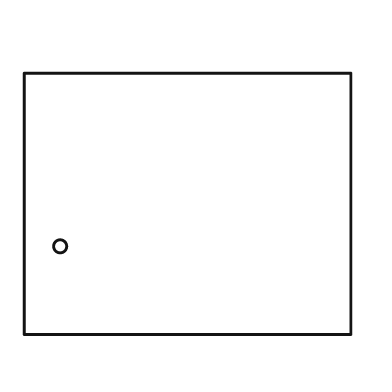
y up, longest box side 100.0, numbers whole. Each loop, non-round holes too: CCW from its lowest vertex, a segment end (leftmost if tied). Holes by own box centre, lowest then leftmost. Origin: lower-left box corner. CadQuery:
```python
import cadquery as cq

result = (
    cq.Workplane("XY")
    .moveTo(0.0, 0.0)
    .lineTo(100.0, 0.0)
    .lineTo(100.0, 80.0)
    .lineTo(0.0, 80.0)
    .close()
    .moveTo(11.0, 27.0)
    .circle(2.0)
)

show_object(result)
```